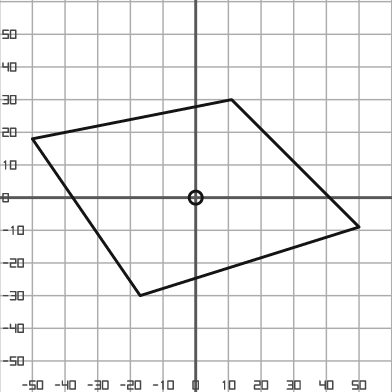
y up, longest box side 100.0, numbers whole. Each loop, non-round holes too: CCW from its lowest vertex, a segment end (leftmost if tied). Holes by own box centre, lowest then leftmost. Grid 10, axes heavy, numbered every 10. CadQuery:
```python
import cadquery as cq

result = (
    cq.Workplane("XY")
    .moveTo(-17.0, -30.0)
    .lineTo(50.0, -9.0)
    .lineTo(11.0, 30.0)
    .lineTo(-50.0, 18.0)
    .close()
    .moveTo(0.0, 0.0)
    .circle(2.0)
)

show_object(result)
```